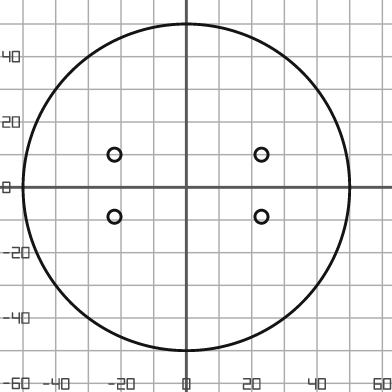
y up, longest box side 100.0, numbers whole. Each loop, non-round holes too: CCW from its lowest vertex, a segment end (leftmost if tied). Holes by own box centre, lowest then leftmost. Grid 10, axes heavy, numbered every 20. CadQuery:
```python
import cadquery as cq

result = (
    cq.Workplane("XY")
    .moveTo(0.0, 0.0)
    .circle(50.0)
    .moveTo(-22.0, -9.0)
    .circle(2.0)
    .moveTo(23.0, -9.0)
    .circle(2.0)
    .moveTo(-22.0, 10.0)
    .circle(2.0)
    .moveTo(23.0, 10.0)
    .circle(2.0)
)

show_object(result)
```